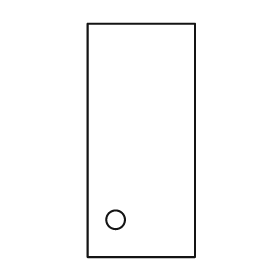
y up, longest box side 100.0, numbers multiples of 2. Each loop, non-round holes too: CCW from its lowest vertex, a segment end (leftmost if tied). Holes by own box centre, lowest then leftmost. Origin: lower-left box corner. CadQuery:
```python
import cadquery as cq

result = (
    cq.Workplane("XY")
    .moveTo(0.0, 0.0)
    .lineTo(46.0, 0.0)
    .lineTo(46.0, 100.0)
    .lineTo(0.0, 100.0)
    .close()
    .moveTo(12.0, 16.0)
    .circle(4.0)
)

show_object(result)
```